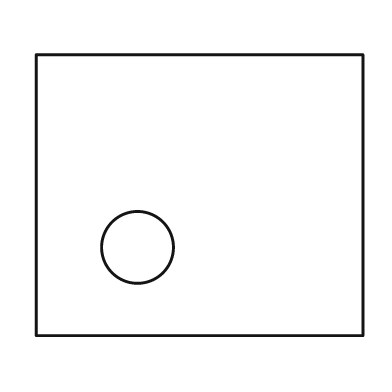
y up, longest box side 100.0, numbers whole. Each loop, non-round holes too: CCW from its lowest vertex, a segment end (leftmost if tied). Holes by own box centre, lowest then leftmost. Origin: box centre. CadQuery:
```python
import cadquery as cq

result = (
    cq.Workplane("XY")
    .moveTo(-50.0, -43.0)
    .lineTo(50.0, -43.0)
    .lineTo(50.0, 43.0)
    .lineTo(-50.0, 43.0)
    .close()
    .moveTo(-19.0, -16.0)
    .circle(11.0)
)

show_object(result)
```